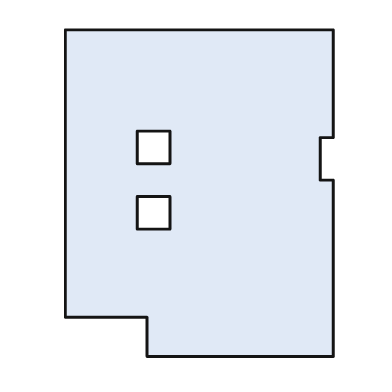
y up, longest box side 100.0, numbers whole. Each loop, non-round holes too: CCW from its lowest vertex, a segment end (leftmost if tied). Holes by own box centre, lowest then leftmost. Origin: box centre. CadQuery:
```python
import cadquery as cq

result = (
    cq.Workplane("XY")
    .moveTo(-16.0, -50.0)
    .lineTo(41.0, -50.0)
    .lineTo(41.0, 4.0)
    .lineTo(37.0, 4.0)
    .lineTo(37.0, 17.0)
    .lineTo(41.0, 17.0)
    .lineTo(41.0, 50.0)
    .lineTo(-41.0, 50.0)
    .lineTo(-41.0, -38.0)
    .lineTo(-16.0, -38.0)
    .close()
    .moveTo(-19.0, -11.0)
    .lineTo(-9.0, -11.0)
    .lineTo(-9.0, -1.0)
    .lineTo(-19.0, -1.0)
    .close()
    .moveTo(-19.0, 9.0)
    .lineTo(-9.0, 9.0)
    .lineTo(-9.0, 19.0)
    .lineTo(-19.0, 19.0)
    .close()
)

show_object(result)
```